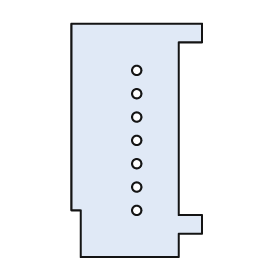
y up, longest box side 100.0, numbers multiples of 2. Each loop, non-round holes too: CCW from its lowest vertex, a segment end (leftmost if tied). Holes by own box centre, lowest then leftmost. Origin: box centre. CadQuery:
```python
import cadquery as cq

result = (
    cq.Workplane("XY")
    .moveTo(-24.0, -50.0)
    .lineTo(18.0, -50.0)
    .lineTo(18.0, -40.0)
    .lineTo(28.0, -40.0)
    .lineTo(28.0, -32.0)
    .lineTo(18.0, -32.0)
    .lineTo(18.0, 42.0)
    .lineTo(28.0, 42.0)
    .lineTo(28.0, 50.0)
    .lineTo(-28.0, 50.0)
    .lineTo(-28.0, -30.0)
    .lineTo(-24.0, -30.0)
    .close()
    .moveTo(0.0, -30.0)
    .circle(2.0)
    .moveTo(0.0, -20.0)
    .circle(2.0)
    .moveTo(0.0, -10.0)
    .circle(2.0)
    .moveTo(0.0, 0.0)
    .circle(2.0)
    .moveTo(0.0, 10.0)
    .circle(2.0)
    .moveTo(0.0, 20.0)
    .circle(2.0)
    .moveTo(0.0, 30.0)
    .circle(2.0)
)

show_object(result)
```